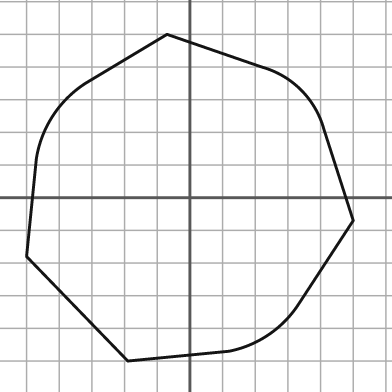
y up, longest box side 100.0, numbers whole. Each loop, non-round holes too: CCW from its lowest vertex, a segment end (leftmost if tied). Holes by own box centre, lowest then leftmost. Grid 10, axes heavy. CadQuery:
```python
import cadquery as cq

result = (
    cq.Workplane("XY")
    .moveTo(-19.0, -50.0)
    .lineTo(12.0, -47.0)
    .threePointArc((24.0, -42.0), (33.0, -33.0))
    .lineTo(50.0, -7.0)
    .lineTo(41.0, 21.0)
    .threePointArc((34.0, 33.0), (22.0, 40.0))
    .lineTo(-7.0, 50.0)
    .lineTo(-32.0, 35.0)
    .threePointArc((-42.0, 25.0), (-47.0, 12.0))
    .lineTo(-50.0, -18.0)
    .close()
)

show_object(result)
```